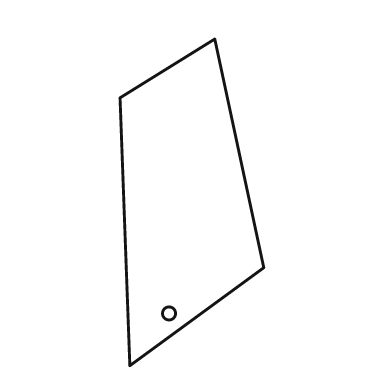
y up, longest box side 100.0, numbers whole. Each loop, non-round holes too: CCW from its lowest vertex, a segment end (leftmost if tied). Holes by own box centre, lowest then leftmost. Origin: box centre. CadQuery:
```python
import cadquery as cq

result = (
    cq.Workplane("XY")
    .moveTo(-19.0, -50.0)
    .lineTo(22.0, -20.0)
    .lineTo(7.0, 50.0)
    .lineTo(-22.0, 32.0)
    .close()
    .moveTo(-7.0, -34.0)
    .circle(2.0)
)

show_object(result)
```